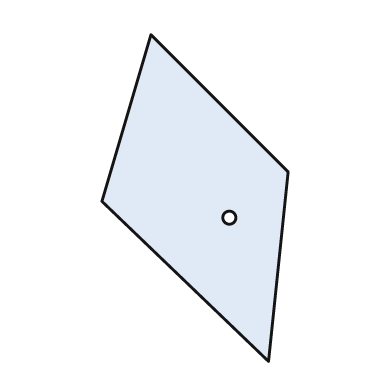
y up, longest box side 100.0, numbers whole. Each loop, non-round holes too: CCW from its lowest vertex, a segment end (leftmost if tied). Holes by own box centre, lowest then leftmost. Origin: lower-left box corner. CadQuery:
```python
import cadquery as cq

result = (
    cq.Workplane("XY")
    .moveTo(51.0, 0.0)
    .lineTo(57.0, 58.0)
    .lineTo(15.0, 100.0)
    .lineTo(0.0, 49.0)
    .close()
    .moveTo(39.0, 44.0)
    .circle(2.0)
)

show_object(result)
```